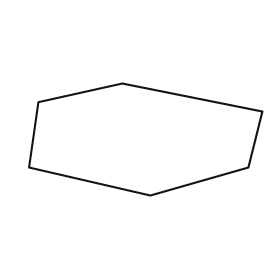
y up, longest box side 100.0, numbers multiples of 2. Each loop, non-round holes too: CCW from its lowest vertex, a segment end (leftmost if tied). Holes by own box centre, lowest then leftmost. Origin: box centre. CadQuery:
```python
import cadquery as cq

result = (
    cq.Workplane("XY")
    .moveTo(2.0, -24.0)
    .lineTo(44.0, -12.0)
    .lineTo(50.0, 12.0)
    .lineTo(-10.0, 24.0)
    .lineTo(-46.0, 16.0)
    .lineTo(-50.0, -12.0)
    .close()
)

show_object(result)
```